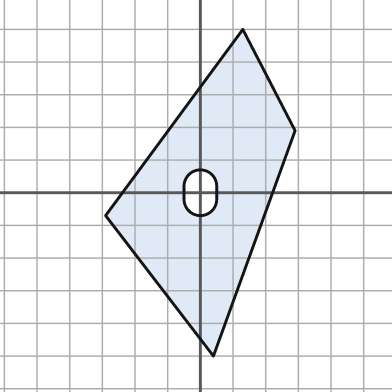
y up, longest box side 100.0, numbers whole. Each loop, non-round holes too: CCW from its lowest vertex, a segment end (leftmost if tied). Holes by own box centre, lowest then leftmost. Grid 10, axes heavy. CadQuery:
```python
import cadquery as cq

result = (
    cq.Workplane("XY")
    .moveTo(4.0, -50.0)
    .lineTo(29.0, 19.0)
    .lineTo(13.0, 50.0)
    .lineTo(-29.0, -7.0)
    .close()
    .moveTo(-5.0, -2.0)
    .threePointArc((0.0, -7.0), (5.0, -2.0))
    .lineTo(5.0, 2.0)
    .threePointArc((0.0, 7.0), (-5.0, 2.0))
    .close()
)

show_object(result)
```